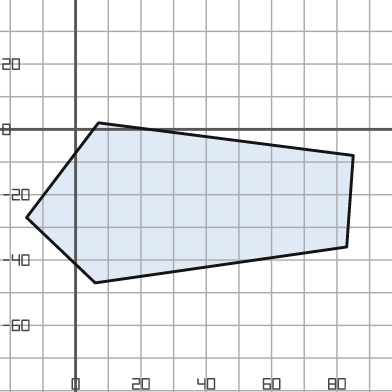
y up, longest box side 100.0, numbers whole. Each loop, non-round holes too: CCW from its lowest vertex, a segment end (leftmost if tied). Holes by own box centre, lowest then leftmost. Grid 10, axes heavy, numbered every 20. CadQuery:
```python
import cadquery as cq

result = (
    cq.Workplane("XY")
    .moveTo(6.0, -47.0)
    .lineTo(83.0, -36.0)
    .lineTo(85.0, -8.0)
    .lineTo(7.0, 2.0)
    .lineTo(-15.0, -27.0)
    .close()
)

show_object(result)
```